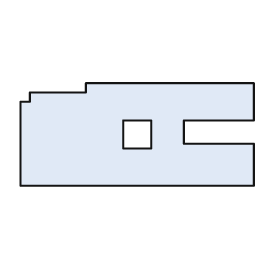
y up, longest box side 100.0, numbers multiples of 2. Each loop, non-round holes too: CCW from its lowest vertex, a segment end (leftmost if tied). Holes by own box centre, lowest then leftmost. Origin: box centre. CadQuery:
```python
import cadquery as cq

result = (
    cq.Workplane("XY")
    .moveTo(-50.0, -22.0)
    .lineTo(50.0, -22.0)
    .lineTo(50.0, -4.0)
    .lineTo(20.0, -4.0)
    .lineTo(20.0, 6.0)
    .lineTo(50.0, 6.0)
    .lineTo(50.0, 22.0)
    .lineTo(-22.0, 22.0)
    .lineTo(-22.0, 18.0)
    .lineTo(-46.0, 18.0)
    .lineTo(-46.0, 14.0)
    .lineTo(-50.0, 14.0)
    .close()
    .moveTo(-6.0, -6.0)
    .lineTo(6.0, -6.0)
    .lineTo(6.0, 6.0)
    .lineTo(-6.0, 6.0)
    .close()
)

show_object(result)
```